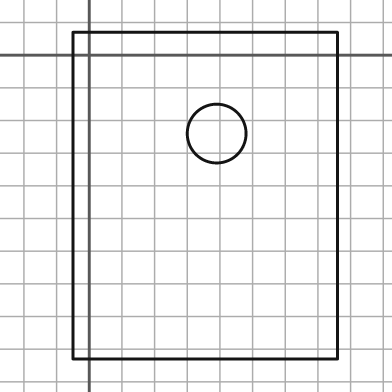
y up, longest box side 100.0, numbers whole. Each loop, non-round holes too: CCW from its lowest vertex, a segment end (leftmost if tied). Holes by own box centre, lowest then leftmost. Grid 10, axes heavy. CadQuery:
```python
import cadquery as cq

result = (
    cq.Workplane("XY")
    .moveTo(-5.0, -93.0)
    .lineTo(76.0, -93.0)
    .lineTo(76.0, 7.0)
    .lineTo(-5.0, 7.0)
    .close()
    .moveTo(39.0, -24.0)
    .circle(9.0)
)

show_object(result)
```